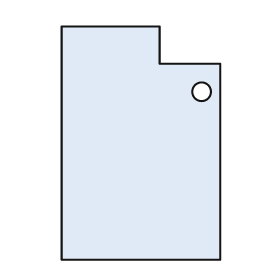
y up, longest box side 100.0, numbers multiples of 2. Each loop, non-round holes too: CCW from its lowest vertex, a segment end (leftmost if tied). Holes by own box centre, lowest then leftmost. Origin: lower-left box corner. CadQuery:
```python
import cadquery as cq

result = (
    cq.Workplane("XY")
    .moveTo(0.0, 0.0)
    .lineTo(68.0, 0.0)
    .lineTo(68.0, 84.0)
    .lineTo(42.0, 84.0)
    .lineTo(42.0, 100.0)
    .lineTo(0.0, 100.0)
    .close()
    .moveTo(60.0, 72.0)
    .circle(4.0)
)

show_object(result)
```